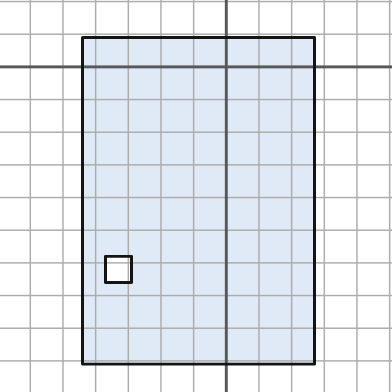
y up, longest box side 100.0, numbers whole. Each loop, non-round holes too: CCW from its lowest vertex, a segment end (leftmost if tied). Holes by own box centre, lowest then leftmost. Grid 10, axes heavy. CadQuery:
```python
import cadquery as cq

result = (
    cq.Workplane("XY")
    .moveTo(-44.0, -91.0)
    .lineTo(27.0, -91.0)
    .lineTo(27.0, 9.0)
    .lineTo(-44.0, 9.0)
    .close()
    .moveTo(-37.0, -66.0)
    .lineTo(-29.0, -66.0)
    .lineTo(-29.0, -58.0)
    .lineTo(-37.0, -58.0)
    .close()
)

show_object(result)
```